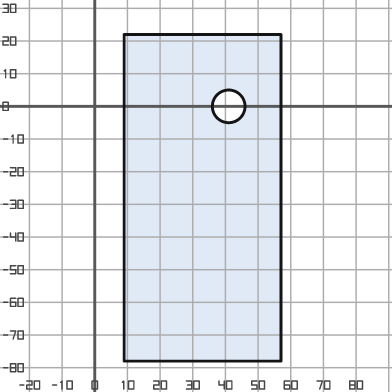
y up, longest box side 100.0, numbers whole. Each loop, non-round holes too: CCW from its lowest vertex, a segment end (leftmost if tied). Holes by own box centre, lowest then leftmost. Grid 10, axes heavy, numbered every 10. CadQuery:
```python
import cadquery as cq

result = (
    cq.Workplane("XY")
    .moveTo(9.0, -78.0)
    .lineTo(57.0, -78.0)
    .lineTo(57.0, 22.0)
    .lineTo(9.0, 22.0)
    .close()
    .moveTo(41.0, 0.0)
    .circle(5.0)
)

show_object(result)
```